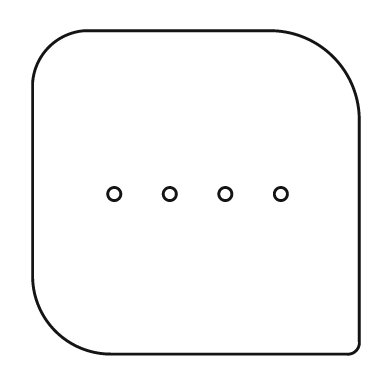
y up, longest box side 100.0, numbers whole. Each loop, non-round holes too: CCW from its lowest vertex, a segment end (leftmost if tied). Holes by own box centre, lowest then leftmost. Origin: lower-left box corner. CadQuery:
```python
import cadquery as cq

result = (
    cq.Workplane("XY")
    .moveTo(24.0, 0.0)
    .lineTo(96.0, 0.0)
    .threePointArc((99.0, 1.0), (100.0, 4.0))
    .lineTo(100.0, 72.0)
    .threePointArc((92.0, 91.0), (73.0, 99.0))
    .lineTo(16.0, 99.0)
    .threePointArc((5.0, 94.0), (0.0, 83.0))
    .lineTo(0.0, 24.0)
    .threePointArc((7.0, 7.0), (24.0, 0.0))
    .close()
    .moveTo(25.0, 49.0)
    .circle(2.0)
    .moveTo(42.0, 49.0)
    .circle(2.0)
    .moveTo(59.0, 49.0)
    .circle(2.0)
    .moveTo(76.0, 49.0)
    .circle(2.0)
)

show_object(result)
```